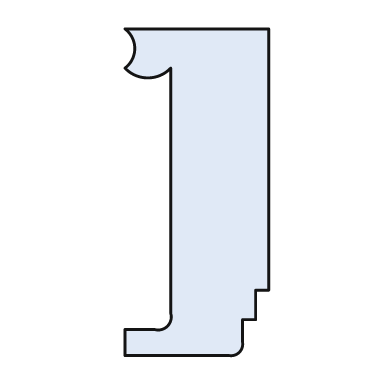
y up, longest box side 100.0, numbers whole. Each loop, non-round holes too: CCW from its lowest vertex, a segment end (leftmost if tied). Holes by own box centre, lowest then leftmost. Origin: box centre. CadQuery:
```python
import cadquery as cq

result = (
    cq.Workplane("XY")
    .moveTo(-22.0, -50.0)
    .lineTo(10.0, -50.0)
    .threePointArc((13.0, -49.0), (14.0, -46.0))
    .lineTo(14.0, -39.0)
    .lineTo(18.0, -39.0)
    .lineTo(18.0, -30.0)
    .lineTo(22.0, -30.0)
    .lineTo(22.0, 50.0)
    .lineTo(-22.0, 50.0)
    .threePointArc((-19.0, 44.0), (-22.0, 38.0))
    .threePointArc((-15.0, 35.0), (-8.0, 38.0))
    .lineTo(-8.0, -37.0)
    .threePointArc((-9.0, -41.0), (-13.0, -42.0))
    .lineTo(-22.0, -42.0)
    .close()
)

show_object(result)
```